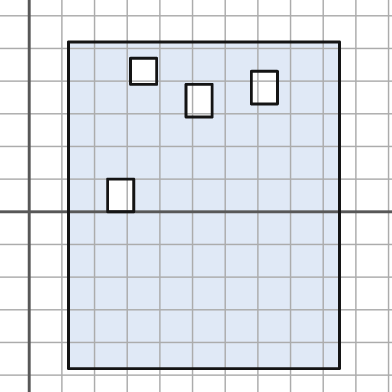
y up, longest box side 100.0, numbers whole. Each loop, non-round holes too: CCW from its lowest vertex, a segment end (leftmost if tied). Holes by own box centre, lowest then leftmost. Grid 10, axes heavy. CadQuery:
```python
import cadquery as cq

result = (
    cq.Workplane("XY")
    .moveTo(12.0, -48.0)
    .lineTo(95.0, -48.0)
    .lineTo(95.0, 52.0)
    .lineTo(12.0, 52.0)
    .close()
    .moveTo(24.0, 0.0)
    .lineTo(32.0, 0.0)
    .lineTo(32.0, 10.0)
    .lineTo(24.0, 10.0)
    .close()
    .moveTo(48.0, 29.0)
    .lineTo(56.0, 29.0)
    .lineTo(56.0, 39.0)
    .lineTo(48.0, 39.0)
    .close()
    .moveTo(68.0, 33.0)
    .lineTo(76.0, 33.0)
    .lineTo(76.0, 43.0)
    .lineTo(68.0, 43.0)
    .close()
    .moveTo(31.0, 39.0)
    .lineTo(39.0, 39.0)
    .lineTo(39.0, 47.0)
    .lineTo(31.0, 47.0)
    .close()
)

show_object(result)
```